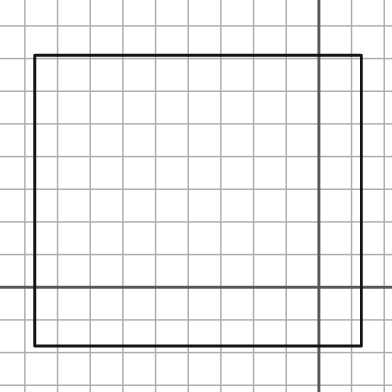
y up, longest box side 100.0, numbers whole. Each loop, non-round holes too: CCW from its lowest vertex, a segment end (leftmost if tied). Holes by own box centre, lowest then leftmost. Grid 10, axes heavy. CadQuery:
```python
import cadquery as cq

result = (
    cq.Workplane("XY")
    .moveTo(-87.0, -18.0)
    .lineTo(13.0, -18.0)
    .lineTo(13.0, 71.0)
    .lineTo(-87.0, 71.0)
    .close()
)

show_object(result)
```